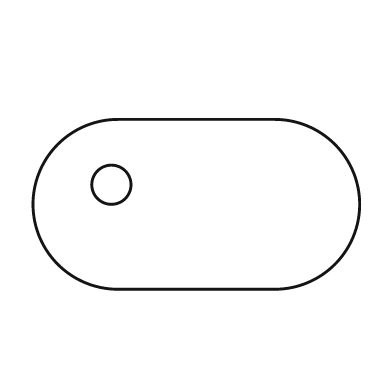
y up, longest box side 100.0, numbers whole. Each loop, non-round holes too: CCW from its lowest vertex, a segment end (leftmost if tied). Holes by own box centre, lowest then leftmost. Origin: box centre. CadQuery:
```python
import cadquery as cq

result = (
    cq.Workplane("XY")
    .moveTo(-24.0, -26.0)
    .lineTo(24.0, -26.0)
    .threePointArc((50.0, 0.0), (24.0, 26.0))
    .lineTo(-24.0, 26.0)
    .threePointArc((-50.0, 0.0), (-24.0, -26.0))
    .close()
    .moveTo(-26.0, 6.0)
    .circle(6.0)
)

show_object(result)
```